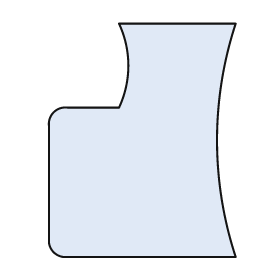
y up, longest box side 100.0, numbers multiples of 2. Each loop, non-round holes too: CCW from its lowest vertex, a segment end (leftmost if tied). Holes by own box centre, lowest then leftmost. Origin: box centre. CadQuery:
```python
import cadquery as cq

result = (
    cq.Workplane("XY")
    .moveTo(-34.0, -50.0)
    .lineTo(40.0, -50.0)
    .threePointArc((32.0, 0.0), (40.0, 50.0))
    .lineTo(-10.0, 50.0)
    .threePointArc((-6.0, 32.0), (-10.0, 14.0))
    .lineTo(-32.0, 14.0)
    .threePointArc((-38.0, 12.0), (-40.0, 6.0))
    .lineTo(-40.0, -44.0)
    .threePointArc((-38.0, -48.0), (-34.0, -50.0))
    .close()
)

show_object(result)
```